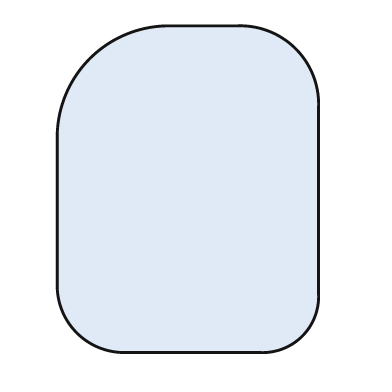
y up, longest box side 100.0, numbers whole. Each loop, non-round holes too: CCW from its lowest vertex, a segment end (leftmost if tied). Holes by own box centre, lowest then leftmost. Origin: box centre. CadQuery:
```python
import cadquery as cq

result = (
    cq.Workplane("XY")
    .moveTo(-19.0, -50.0)
    .lineTo(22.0, -50.0)
    .threePointArc((35.0, -45.0), (40.0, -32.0))
    .lineTo(40.0, 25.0)
    .threePointArc((33.0, 43.0), (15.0, 50.0))
    .lineTo(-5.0, 50.0)
    .threePointArc((-30.0, 40.0), (-40.0, 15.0))
    .lineTo(-40.0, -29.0)
    .threePointArc((-34.0, -44.0), (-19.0, -50.0))
    .close()
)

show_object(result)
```